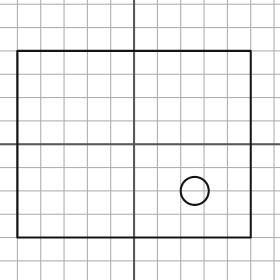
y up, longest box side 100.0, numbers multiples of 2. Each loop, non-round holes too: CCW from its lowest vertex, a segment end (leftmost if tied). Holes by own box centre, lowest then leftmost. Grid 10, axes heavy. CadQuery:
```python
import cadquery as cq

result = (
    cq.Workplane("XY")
    .moveTo(-50.0, -40.0)
    .lineTo(50.0, -40.0)
    .lineTo(50.0, 40.0)
    .lineTo(-50.0, 40.0)
    .close()
    .moveTo(26.0, -20.0)
    .circle(6.0)
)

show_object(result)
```